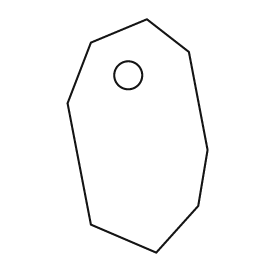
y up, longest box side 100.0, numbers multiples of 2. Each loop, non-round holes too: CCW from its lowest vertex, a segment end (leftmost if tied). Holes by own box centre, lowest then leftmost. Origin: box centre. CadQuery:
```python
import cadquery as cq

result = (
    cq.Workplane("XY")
    .moveTo(8.0, -50.0)
    .lineTo(26.0, -30.0)
    .lineTo(30.0, -6.0)
    .lineTo(22.0, 36.0)
    .lineTo(4.0, 50.0)
    .lineTo(-20.0, 40.0)
    .lineTo(-30.0, 14.0)
    .lineTo(-20.0, -38.0)
    .close()
    .moveTo(-4.0, 26.0)
    .circle(6.0)
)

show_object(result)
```